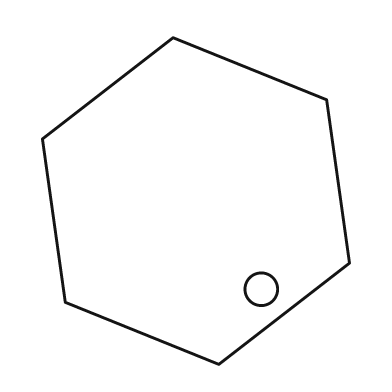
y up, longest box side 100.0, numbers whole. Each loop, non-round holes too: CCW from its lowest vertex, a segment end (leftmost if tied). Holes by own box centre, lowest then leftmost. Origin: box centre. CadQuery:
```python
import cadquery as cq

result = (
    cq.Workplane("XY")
    .moveTo(7.0, -50.0)
    .lineTo(47.0, -19.0)
    .lineTo(40.0, 31.0)
    .lineTo(-7.0, 50.0)
    .lineTo(-47.0, 19.0)
    .lineTo(-40.0, -31.0)
    .close()
    .moveTo(20.0, -27.0)
    .circle(5.0)
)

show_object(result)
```